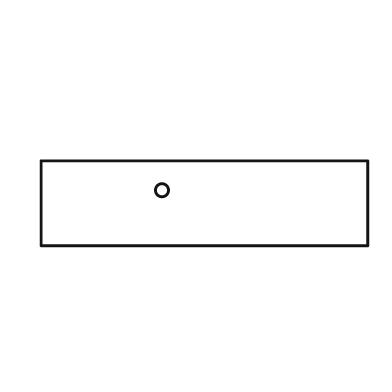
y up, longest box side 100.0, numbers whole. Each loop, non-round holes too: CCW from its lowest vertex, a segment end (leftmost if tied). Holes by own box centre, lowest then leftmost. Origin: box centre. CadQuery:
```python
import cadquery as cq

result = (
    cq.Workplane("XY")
    .moveTo(-50.0, -13.0)
    .lineTo(50.0, -13.0)
    .lineTo(50.0, 13.0)
    .lineTo(-50.0, 13.0)
    .close()
    .moveTo(-13.0, 4.0)
    .circle(2.0)
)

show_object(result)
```